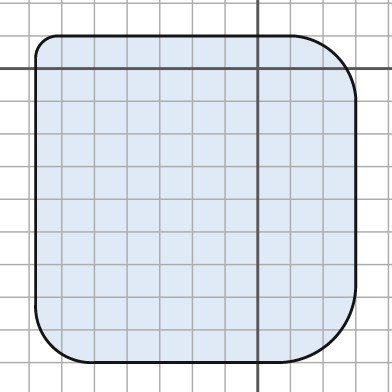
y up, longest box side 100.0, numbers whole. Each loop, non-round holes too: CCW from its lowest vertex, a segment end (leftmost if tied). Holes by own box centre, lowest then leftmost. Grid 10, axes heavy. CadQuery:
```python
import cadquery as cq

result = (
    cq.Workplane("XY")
    .moveTo(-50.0, -90.0)
    .lineTo(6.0, -90.0)
    .threePointArc((23.0, -83.0), (30.0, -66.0))
    .lineTo(30.0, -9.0)
    .threePointArc((24.0, 4.0), (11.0, 10.0))
    .lineTo(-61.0, 10.0)
    .threePointArc((-66.0, 8.0), (-68.0, 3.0))
    .lineTo(-68.0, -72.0)
    .threePointArc((-63.0, -85.0), (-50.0, -90.0))
    .close()
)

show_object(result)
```